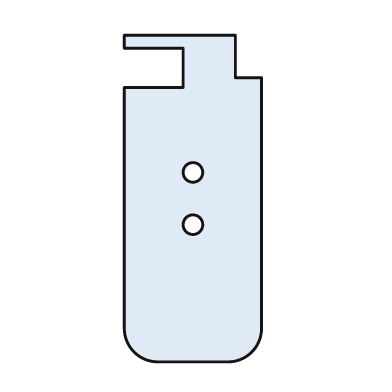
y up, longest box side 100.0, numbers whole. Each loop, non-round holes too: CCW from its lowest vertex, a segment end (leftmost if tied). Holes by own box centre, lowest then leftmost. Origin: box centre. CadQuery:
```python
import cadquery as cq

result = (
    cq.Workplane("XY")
    .moveTo(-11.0, -50.0)
    .lineTo(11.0, -50.0)
    .threePointArc((18.0, -47.0), (21.0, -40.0))
    .lineTo(21.0, 37.0)
    .lineTo(13.0, 37.0)
    .lineTo(13.0, 50.0)
    .lineTo(-21.0, 50.0)
    .lineTo(-21.0, 46.0)
    .lineTo(-3.0, 46.0)
    .lineTo(-3.0, 34.0)
    .lineTo(-21.0, 34.0)
    .lineTo(-21.0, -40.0)
    .threePointArc((-18.0, -47.0), (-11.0, -50.0))
    .close()
    .moveTo(0.0, -8.0)
    .circle(3.0)
    .moveTo(0.0, 8.0)
    .circle(3.0)
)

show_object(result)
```